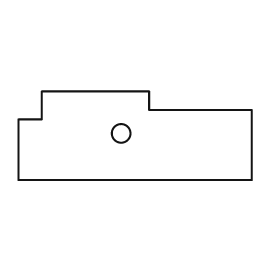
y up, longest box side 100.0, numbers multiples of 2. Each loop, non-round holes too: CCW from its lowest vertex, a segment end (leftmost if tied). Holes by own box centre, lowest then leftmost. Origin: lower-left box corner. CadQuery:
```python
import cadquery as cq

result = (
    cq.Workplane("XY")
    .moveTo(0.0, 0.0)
    .lineTo(100.0, 0.0)
    .lineTo(100.0, 30.0)
    .lineTo(56.0, 30.0)
    .lineTo(56.0, 38.0)
    .lineTo(10.0, 38.0)
    .lineTo(10.0, 26.0)
    .lineTo(0.0, 26.0)
    .close()
    .moveTo(44.0, 20.0)
    .circle(4.0)
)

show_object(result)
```